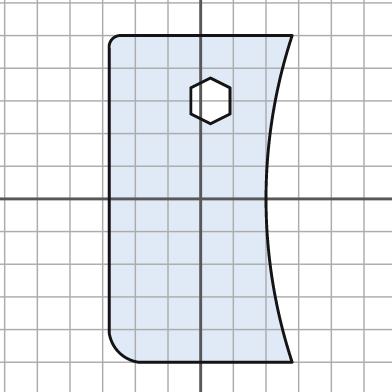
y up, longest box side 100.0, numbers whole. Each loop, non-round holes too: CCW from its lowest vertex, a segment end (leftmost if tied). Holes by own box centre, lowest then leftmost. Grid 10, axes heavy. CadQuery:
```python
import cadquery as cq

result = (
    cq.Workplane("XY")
    .moveTo(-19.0, -50.0)
    .lineTo(28.0, -50.0)
    .threePointArc((20.0, 0.0), (28.0, 50.0))
    .lineTo(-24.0, 50.0)
    .threePointArc((-27.0, 49.0), (-28.0, 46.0))
    .lineTo(-28.0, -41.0)
    .threePointArc((-25.0, -47.0), (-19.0, -50.0))
    .close()
    .moveTo(3.0, 23.0)
    .lineTo(9.0, 26.0)
    .lineTo(9.0, 34.0)
    .lineTo(3.0, 37.0)
    .lineTo(-3.0, 34.0)
    .lineTo(-3.0, 26.0)
    .close()
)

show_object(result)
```